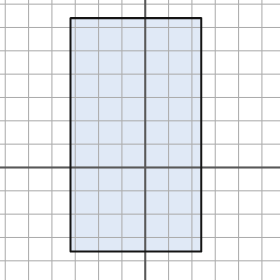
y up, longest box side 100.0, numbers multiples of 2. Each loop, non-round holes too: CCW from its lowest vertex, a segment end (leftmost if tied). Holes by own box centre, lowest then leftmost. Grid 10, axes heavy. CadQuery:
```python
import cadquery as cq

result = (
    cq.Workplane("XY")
    .moveTo(-32.0, -36.0)
    .lineTo(24.0, -36.0)
    .lineTo(24.0, 64.0)
    .lineTo(-32.0, 64.0)
    .close()
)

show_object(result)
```